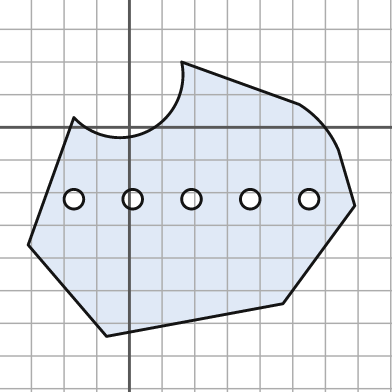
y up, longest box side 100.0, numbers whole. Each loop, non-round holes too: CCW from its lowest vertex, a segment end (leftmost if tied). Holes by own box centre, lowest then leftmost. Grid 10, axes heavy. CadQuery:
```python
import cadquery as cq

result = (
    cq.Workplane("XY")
    .moveTo(-7.0, -64.0)
    .lineTo(47.0, -54.0)
    .lineTo(69.0, -24.0)
    .lineTo(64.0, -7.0)
    .threePointArc((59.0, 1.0), (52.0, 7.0))
    .lineTo(16.0, 20.0)
    .threePointArc((6.0, -1.0), (-17.0, 3.0))
    .lineTo(-31.0, -36.0)
    .close()
    .moveTo(-17.0, -22.0)
    .circle(3.0)
    .moveTo(1.0, -22.0)
    .circle(3.0)
    .moveTo(19.0, -22.0)
    .circle(3.0)
    .moveTo(37.0, -22.0)
    .circle(3.0)
    .moveTo(55.0, -22.0)
    .circle(3.0)
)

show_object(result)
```